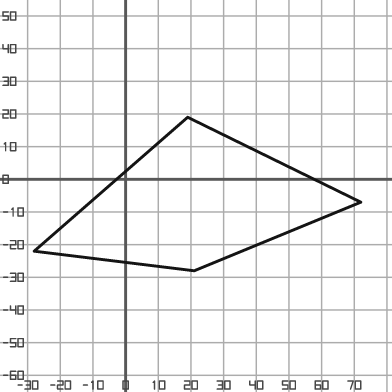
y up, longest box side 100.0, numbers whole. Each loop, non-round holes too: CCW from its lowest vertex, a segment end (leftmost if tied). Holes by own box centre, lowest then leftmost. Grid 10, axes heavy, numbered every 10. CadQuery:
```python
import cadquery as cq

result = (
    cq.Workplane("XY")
    .moveTo(21.0, -28.0)
    .lineTo(72.0, -7.0)
    .lineTo(19.0, 19.0)
    .lineTo(-28.0, -22.0)
    .close()
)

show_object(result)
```